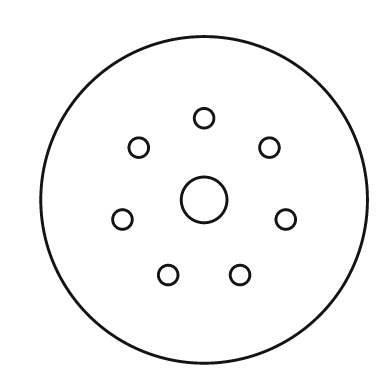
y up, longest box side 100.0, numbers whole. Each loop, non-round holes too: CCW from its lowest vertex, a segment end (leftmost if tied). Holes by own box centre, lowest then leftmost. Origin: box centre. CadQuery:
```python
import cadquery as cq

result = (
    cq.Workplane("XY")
    .moveTo(0.0, 0.0)
    .circle(50.0)
    .moveTo(-11.0, -23.0)
    .circle(3.0)
    .moveTo(11.0, -23.0)
    .circle(3.0)
    .moveTo(-25.0, -6.0)
    .circle(3.0)
    .moveTo(25.0, -6.0)
    .circle(3.0)
    .moveTo(0.0, 0.0)
    .circle(7.0)
    .moveTo(-20.0, 16.0)
    .circle(3.0)
    .moveTo(20.0, 16.0)
    .circle(3.0)
    .moveTo(0.0, 25.0)
    .circle(3.0)
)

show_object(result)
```